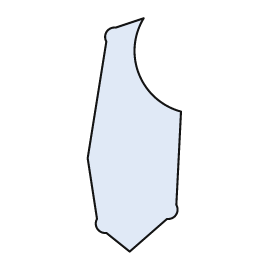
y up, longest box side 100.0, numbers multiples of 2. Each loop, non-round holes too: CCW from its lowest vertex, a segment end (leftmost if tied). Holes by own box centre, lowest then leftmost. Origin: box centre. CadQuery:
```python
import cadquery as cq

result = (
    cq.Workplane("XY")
    .moveTo(-2.0, -50.0)
    .lineTo(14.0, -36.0)
    .threePointArc((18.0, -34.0), (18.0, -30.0))
    .lineTo(20.0, 10.0)
    .threePointArc((2.0, 26.0), (4.0, 50.0))
    .lineTo(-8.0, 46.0)
    .threePointArc((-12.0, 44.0), (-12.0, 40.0))
    .lineTo(-20.0, -10.0)
    .lineTo(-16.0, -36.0)
    .threePointArc((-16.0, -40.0), (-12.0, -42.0))
    .close()
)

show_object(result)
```